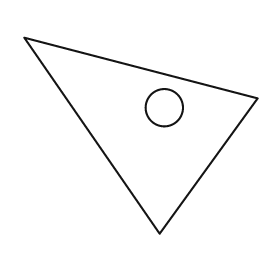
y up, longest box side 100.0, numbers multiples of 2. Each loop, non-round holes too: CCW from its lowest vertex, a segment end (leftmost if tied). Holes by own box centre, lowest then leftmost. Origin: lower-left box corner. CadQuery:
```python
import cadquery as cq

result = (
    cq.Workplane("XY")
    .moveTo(58.0, 0.0)
    .lineTo(100.0, 58.0)
    .lineTo(0.0, 84.0)
    .close()
    .moveTo(60.0, 54.0)
    .circle(8.0)
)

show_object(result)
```